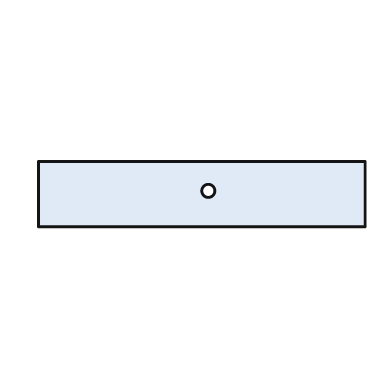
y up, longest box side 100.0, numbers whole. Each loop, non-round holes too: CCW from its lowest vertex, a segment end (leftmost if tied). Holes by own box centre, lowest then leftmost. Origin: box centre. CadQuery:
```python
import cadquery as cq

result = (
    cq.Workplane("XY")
    .moveTo(-50.0, -10.0)
    .lineTo(50.0, -10.0)
    .lineTo(50.0, 10.0)
    .lineTo(-50.0, 10.0)
    .close()
    .moveTo(2.0, 1.0)
    .circle(2.0)
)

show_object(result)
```